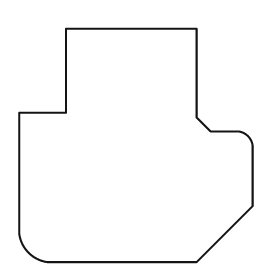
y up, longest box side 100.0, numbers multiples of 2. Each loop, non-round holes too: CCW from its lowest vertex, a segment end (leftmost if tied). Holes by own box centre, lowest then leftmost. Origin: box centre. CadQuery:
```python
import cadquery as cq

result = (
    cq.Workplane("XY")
    .moveTo(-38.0, -50.0)
    .lineTo(26.0, -50.0)
    .lineTo(50.0, -26.0)
    .lineTo(50.0, 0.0)
    .threePointArc((48.0, 4.0), (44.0, 6.0))
    .lineTo(32.0, 6.0)
    .lineTo(26.0, 12.0)
    .lineTo(26.0, 50.0)
    .lineTo(-30.0, 50.0)
    .lineTo(-30.0, 14.0)
    .lineTo(-50.0, 14.0)
    .lineTo(-50.0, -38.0)
    .threePointArc((-46.0, -46.0), (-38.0, -50.0))
    .close()
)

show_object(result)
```